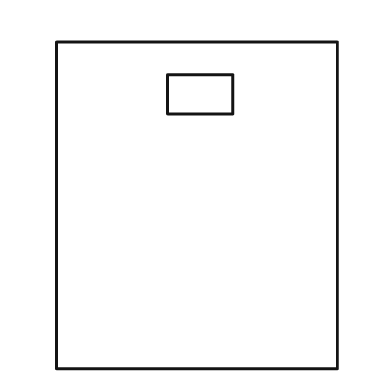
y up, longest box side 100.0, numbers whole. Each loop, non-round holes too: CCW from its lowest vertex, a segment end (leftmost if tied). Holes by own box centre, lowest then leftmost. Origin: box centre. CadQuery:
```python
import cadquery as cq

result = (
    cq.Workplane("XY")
    .moveTo(-43.0, -50.0)
    .lineTo(43.0, -50.0)
    .lineTo(43.0, 50.0)
    .lineTo(-43.0, 50.0)
    .close()
    .moveTo(-9.0, 28.0)
    .lineTo(11.0, 28.0)
    .lineTo(11.0, 40.0)
    .lineTo(-9.0, 40.0)
    .close()
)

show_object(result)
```